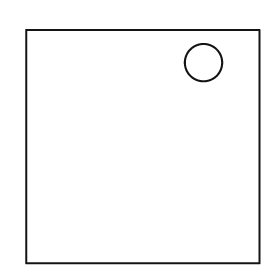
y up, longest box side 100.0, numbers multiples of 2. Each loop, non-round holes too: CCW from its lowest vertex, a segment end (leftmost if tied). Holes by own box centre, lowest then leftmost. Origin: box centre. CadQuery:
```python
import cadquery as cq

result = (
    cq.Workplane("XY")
    .moveTo(-50.0, -50.0)
    .lineTo(50.0, -50.0)
    .lineTo(50.0, 50.0)
    .lineTo(-50.0, 50.0)
    .close()
    .moveTo(26.0, 36.0)
    .circle(8.0)
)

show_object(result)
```